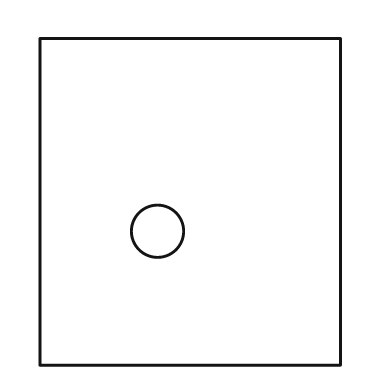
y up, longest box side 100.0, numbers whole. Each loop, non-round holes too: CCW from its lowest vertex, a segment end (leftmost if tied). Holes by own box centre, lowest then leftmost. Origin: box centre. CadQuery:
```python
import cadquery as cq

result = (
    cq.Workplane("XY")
    .moveTo(-46.0, -50.0)
    .lineTo(46.0, -50.0)
    .lineTo(46.0, 50.0)
    .lineTo(-46.0, 50.0)
    .close()
    .moveTo(-10.0, -9.0)
    .circle(8.0)
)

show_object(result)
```